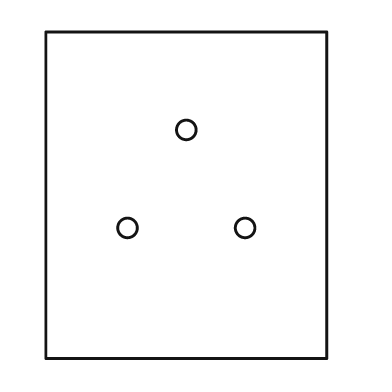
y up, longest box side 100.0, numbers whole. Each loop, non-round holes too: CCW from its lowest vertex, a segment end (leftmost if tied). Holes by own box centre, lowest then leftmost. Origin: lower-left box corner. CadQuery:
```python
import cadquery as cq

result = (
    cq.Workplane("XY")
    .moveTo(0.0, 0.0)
    .lineTo(86.0, 0.0)
    .lineTo(86.0, 100.0)
    .lineTo(0.0, 100.0)
    .close()
    .moveTo(25.0, 40.0)
    .circle(3.0)
    .moveTo(61.0, 40.0)
    .circle(3.0)
    .moveTo(43.0, 70.0)
    .circle(3.0)
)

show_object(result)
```